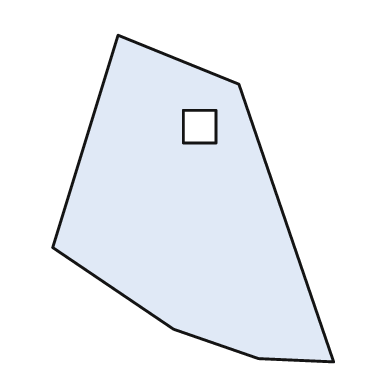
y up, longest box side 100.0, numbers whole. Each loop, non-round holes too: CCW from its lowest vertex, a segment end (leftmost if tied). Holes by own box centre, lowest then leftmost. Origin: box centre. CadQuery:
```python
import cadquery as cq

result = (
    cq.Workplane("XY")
    .moveTo(43.0, -50.0)
    .lineTo(14.0, 35.0)
    .lineTo(-23.0, 50.0)
    .lineTo(-43.0, -15.0)
    .lineTo(-6.0, -40.0)
    .lineTo(20.0, -49.0)
    .close()
    .moveTo(-3.0, 17.0)
    .lineTo(7.0, 17.0)
    .lineTo(7.0, 27.0)
    .lineTo(-3.0, 27.0)
    .close()
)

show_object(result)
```